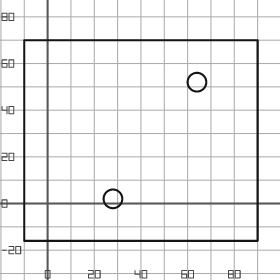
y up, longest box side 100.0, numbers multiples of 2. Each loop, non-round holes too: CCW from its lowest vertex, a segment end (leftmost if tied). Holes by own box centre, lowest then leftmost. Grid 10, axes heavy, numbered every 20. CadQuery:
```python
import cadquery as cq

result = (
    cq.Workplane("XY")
    .moveTo(-10.0, -16.0)
    .lineTo(90.0, -16.0)
    .lineTo(90.0, 70.0)
    .lineTo(-10.0, 70.0)
    .close()
    .moveTo(28.0, 2.0)
    .circle(4.0)
    .moveTo(64.0, 52.0)
    .circle(4.0)
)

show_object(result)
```